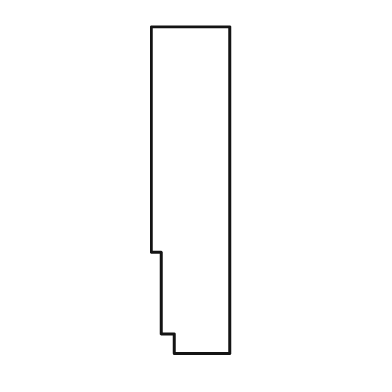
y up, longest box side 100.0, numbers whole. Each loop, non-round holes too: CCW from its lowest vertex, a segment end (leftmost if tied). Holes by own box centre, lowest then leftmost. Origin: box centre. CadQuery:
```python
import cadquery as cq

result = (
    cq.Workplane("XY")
    .moveTo(-5.0, -50.0)
    .lineTo(12.0, -50.0)
    .lineTo(12.0, 50.0)
    .lineTo(-12.0, 50.0)
    .lineTo(-12.0, -19.0)
    .lineTo(-9.0, -19.0)
    .lineTo(-9.0, -44.0)
    .lineTo(-5.0, -44.0)
    .close()
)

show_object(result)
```